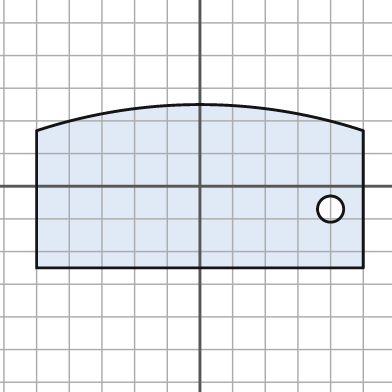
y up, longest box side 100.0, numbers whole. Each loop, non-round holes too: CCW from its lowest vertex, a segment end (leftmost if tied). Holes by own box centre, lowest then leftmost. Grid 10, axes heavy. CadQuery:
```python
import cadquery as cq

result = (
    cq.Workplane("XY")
    .moveTo(-50.0, -25.0)
    .lineTo(50.0, -25.0)
    .lineTo(50.0, 17.0)
    .threePointArc((0.0, 25.0), (-50.0, 17.0))
    .close()
    .moveTo(40.0, -7.0)
    .circle(4.0)
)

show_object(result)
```